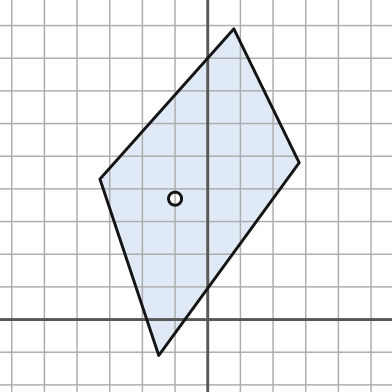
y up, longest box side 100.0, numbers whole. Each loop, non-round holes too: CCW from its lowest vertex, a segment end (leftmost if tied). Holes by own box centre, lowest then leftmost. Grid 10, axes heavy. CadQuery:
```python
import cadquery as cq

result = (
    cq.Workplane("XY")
    .moveTo(-15.0, -11.0)
    .lineTo(28.0, 48.0)
    .lineTo(8.0, 89.0)
    .lineTo(-33.0, 43.0)
    .close()
    .moveTo(-10.0, 37.0)
    .circle(2.0)
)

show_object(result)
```